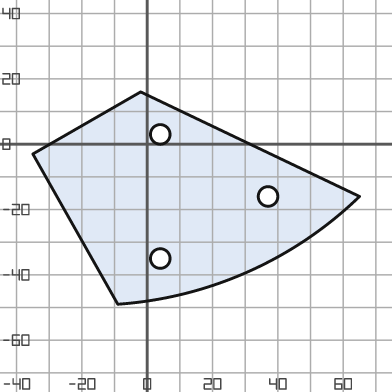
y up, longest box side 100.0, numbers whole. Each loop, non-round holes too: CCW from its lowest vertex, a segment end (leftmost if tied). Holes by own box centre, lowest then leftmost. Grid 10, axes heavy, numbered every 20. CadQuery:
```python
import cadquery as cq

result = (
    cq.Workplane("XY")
    .moveTo(-9.0, -49.0)
    .threePointArc((31.0, -39.0), (65.0, -16.0))
    .lineTo(-2.0, 16.0)
    .lineTo(-35.0, -3.0)
    .close()
    .moveTo(4.0, -35.0)
    .circle(3.0)
    .moveTo(37.0, -16.0)
    .circle(3.0)
    .moveTo(4.0, 3.0)
    .circle(3.0)
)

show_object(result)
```